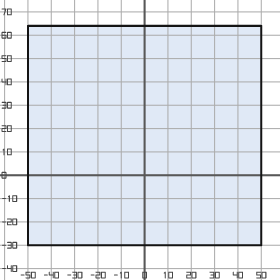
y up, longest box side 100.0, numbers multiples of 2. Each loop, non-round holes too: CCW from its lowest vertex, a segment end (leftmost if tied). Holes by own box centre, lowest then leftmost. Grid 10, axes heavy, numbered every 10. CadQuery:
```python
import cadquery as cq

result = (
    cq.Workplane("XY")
    .moveTo(-50.0, -30.0)
    .lineTo(50.0, -30.0)
    .lineTo(50.0, 64.0)
    .lineTo(-50.0, 64.0)
    .close()
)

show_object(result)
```